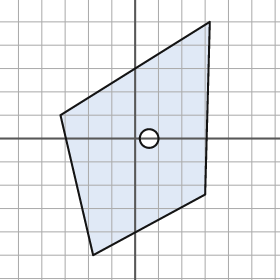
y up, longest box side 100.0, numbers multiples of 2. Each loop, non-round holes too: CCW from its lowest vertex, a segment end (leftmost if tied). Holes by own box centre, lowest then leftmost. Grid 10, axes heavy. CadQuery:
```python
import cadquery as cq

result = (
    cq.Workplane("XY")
    .moveTo(-18.0, -50.0)
    .lineTo(30.0, -24.0)
    .lineTo(32.0, 50.0)
    .lineTo(-32.0, 10.0)
    .close()
    .moveTo(6.0, 0.0)
    .circle(4.0)
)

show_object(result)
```